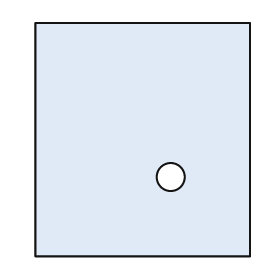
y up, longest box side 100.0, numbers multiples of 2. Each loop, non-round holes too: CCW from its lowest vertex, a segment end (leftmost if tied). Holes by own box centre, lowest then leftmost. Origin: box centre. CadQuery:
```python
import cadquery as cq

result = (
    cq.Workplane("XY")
    .moveTo(-46.0, -50.0)
    .lineTo(46.0, -50.0)
    .lineTo(46.0, 50.0)
    .lineTo(-46.0, 50.0)
    .close()
    .moveTo(12.0, -16.0)
    .circle(6.0)
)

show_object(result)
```